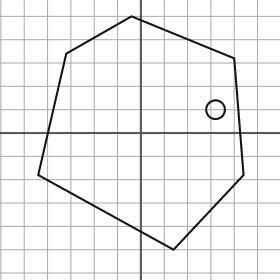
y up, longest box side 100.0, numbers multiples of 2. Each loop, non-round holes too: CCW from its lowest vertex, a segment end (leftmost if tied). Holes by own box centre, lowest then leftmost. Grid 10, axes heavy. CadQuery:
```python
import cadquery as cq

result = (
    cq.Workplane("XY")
    .moveTo(14.0, -50.0)
    .lineTo(44.0, -18.0)
    .lineTo(40.0, 32.0)
    .lineTo(-4.0, 50.0)
    .lineTo(-32.0, 34.0)
    .lineTo(-44.0, -18.0)
    .close()
    .moveTo(32.0, 10.0)
    .circle(4.0)
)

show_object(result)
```